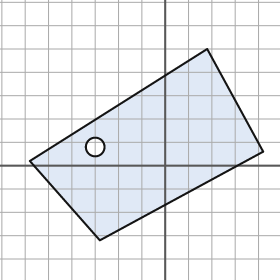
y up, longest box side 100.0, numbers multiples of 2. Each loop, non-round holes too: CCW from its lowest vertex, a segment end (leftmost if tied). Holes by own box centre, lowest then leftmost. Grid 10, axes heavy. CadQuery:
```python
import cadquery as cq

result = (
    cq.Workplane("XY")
    .moveTo(-28.0, -32.0)
    .lineTo(42.0, 6.0)
    .lineTo(18.0, 50.0)
    .lineTo(-58.0, 2.0)
    .close()
    .moveTo(-30.0, 8.0)
    .circle(4.0)
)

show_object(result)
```